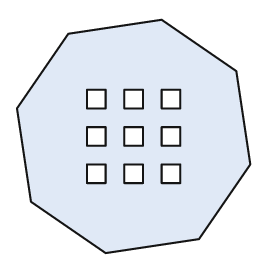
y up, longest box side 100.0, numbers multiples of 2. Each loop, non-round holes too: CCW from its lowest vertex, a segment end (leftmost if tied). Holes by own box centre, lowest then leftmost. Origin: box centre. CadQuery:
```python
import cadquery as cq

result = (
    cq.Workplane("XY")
    .moveTo(-12.0, -50.0)
    .lineTo(28.0, -44.0)
    .lineTo(50.0, -12.0)
    .lineTo(44.0, 28.0)
    .lineTo(12.0, 50.0)
    .lineTo(-28.0, 44.0)
    .lineTo(-50.0, 12.0)
    .lineTo(-44.0, -28.0)
    .close()
    .moveTo(-20.0, -20.0)
    .lineTo(-12.0, -20.0)
    .lineTo(-12.0, -12.0)
    .lineTo(-20.0, -12.0)
    .close()
    .moveTo(-4.0, -20.0)
    .lineTo(4.0, -20.0)
    .lineTo(4.0, -12.0)
    .lineTo(-4.0, -12.0)
    .close()
    .moveTo(12.0, -20.0)
    .lineTo(20.0, -20.0)
    .lineTo(20.0, -12.0)
    .lineTo(12.0, -12.0)
    .close()
    .moveTo(-20.0, -4.0)
    .lineTo(-12.0, -4.0)
    .lineTo(-12.0, 4.0)
    .lineTo(-20.0, 4.0)
    .close()
    .moveTo(-4.0, -4.0)
    .lineTo(4.0, -4.0)
    .lineTo(4.0, 4.0)
    .lineTo(-4.0, 4.0)
    .close()
    .moveTo(12.0, -4.0)
    .lineTo(20.0, -4.0)
    .lineTo(20.0, 4.0)
    .lineTo(12.0, 4.0)
    .close()
    .moveTo(-20.0, 12.0)
    .lineTo(-12.0, 12.0)
    .lineTo(-12.0, 20.0)
    .lineTo(-20.0, 20.0)
    .close()
    .moveTo(-4.0, 12.0)
    .lineTo(4.0, 12.0)
    .lineTo(4.0, 20.0)
    .lineTo(-4.0, 20.0)
    .close()
    .moveTo(12.0, 12.0)
    .lineTo(20.0, 12.0)
    .lineTo(20.0, 20.0)
    .lineTo(12.0, 20.0)
    .close()
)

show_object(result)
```